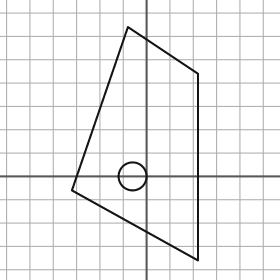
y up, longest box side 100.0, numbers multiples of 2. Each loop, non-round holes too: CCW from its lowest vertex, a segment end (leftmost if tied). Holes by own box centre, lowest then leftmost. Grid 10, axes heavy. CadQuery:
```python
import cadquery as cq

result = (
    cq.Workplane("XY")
    .moveTo(22.0, -36.0)
    .lineTo(22.0, 44.0)
    .lineTo(-8.0, 64.0)
    .lineTo(-32.0, -6.0)
    .close()
    .moveTo(-6.0, 0.0)
    .circle(6.0)
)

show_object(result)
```